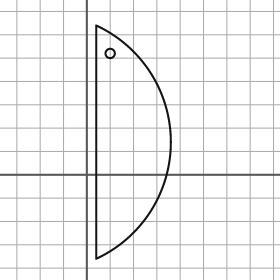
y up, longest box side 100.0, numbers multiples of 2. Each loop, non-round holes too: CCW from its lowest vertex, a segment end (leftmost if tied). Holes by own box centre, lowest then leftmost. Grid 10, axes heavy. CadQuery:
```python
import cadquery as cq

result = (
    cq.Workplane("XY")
    .moveTo(4.0, -36.0)
    .threePointArc((36.0, 14.0), (4.0, 64.0))
    .close()
    .moveTo(10.0, 52.0)
    .circle(2.0)
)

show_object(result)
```